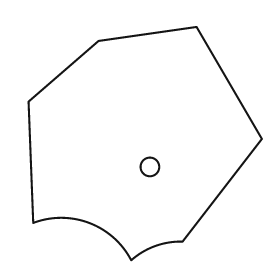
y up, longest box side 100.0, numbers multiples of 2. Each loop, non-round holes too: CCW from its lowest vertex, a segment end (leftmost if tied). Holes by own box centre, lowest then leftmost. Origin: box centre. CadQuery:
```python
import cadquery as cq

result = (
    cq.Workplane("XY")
    .moveTo(-6.0, -50.0)
    .threePointArc((4.0, -44.0), (16.0, -42.0))
    .lineTo(50.0, 2.0)
    .lineTo(22.0, 50.0)
    .lineTo(-20.0, 44.0)
    .lineTo(-50.0, 18.0)
    .lineTo(-48.0, -34.0)
    .threePointArc((-24.0, -34.0), (-6.0, -50.0))
    .close()
    .moveTo(2.0, -10.0)
    .circle(4.0)
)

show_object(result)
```